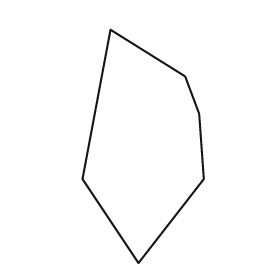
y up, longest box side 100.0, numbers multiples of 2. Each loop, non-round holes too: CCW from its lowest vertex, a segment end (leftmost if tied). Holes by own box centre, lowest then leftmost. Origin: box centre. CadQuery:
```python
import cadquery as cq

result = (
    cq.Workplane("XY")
    .moveTo(-2.0, -50.0)
    .lineTo(26.0, -14.0)
    .lineTo(24.0, 14.0)
    .lineTo(18.0, 30.0)
    .lineTo(-14.0, 50.0)
    .lineTo(-26.0, -14.0)
    .close()
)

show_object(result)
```